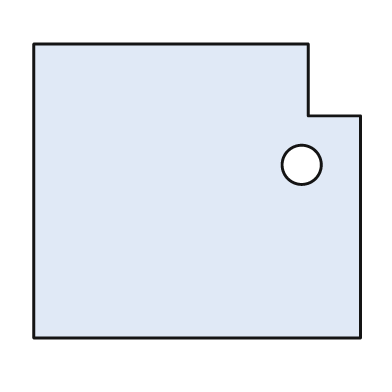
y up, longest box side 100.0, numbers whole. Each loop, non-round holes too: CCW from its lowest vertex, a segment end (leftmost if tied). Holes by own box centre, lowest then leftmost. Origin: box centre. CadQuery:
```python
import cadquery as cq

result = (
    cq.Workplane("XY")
    .moveTo(-50.0, -45.0)
    .lineTo(50.0, -45.0)
    .lineTo(50.0, 23.0)
    .lineTo(34.0, 23.0)
    .lineTo(34.0, 45.0)
    .lineTo(-50.0, 45.0)
    .close()
    .moveTo(32.0, 8.0)
    .circle(6.0)
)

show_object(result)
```